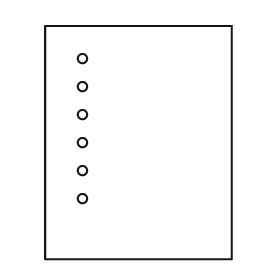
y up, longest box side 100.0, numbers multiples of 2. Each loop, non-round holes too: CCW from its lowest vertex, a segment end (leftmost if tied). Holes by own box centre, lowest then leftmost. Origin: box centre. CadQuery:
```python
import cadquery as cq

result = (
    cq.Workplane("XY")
    .moveTo(-40.0, -50.0)
    .lineTo(40.0, -50.0)
    .lineTo(40.0, 50.0)
    .lineTo(-40.0, 50.0)
    .close()
    .moveTo(-24.0, -24.0)
    .circle(2.0)
    .moveTo(-24.0, -12.0)
    .circle(2.0)
    .moveTo(-24.0, 0.0)
    .circle(2.0)
    .moveTo(-24.0, 12.0)
    .circle(2.0)
    .moveTo(-24.0, 24.0)
    .circle(2.0)
    .moveTo(-24.0, 36.0)
    .circle(2.0)
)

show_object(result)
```